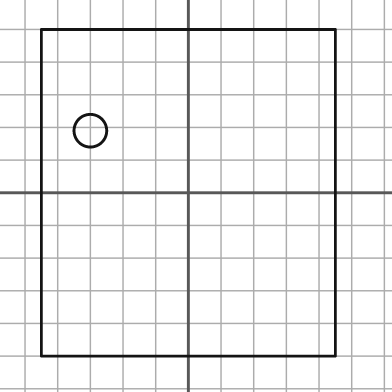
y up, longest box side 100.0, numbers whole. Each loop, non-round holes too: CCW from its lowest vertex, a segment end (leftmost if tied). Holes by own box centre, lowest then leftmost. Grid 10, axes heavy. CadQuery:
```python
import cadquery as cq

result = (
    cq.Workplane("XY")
    .moveTo(-45.0, -50.0)
    .lineTo(45.0, -50.0)
    .lineTo(45.0, 50.0)
    .lineTo(-45.0, 50.0)
    .close()
    .moveTo(-30.0, 19.0)
    .circle(5.0)
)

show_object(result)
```